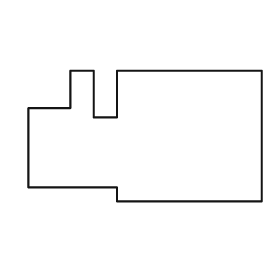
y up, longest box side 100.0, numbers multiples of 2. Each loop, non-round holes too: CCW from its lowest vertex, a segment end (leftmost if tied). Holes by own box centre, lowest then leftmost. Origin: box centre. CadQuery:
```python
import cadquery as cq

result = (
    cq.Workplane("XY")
    .moveTo(-12.0, -28.0)
    .lineTo(50.0, -28.0)
    .lineTo(50.0, 28.0)
    .lineTo(-12.0, 28.0)
    .lineTo(-12.0, 8.0)
    .lineTo(-22.0, 8.0)
    .lineTo(-22.0, 28.0)
    .lineTo(-32.0, 28.0)
    .lineTo(-32.0, 12.0)
    .lineTo(-50.0, 12.0)
    .lineTo(-50.0, -22.0)
    .lineTo(-12.0, -22.0)
    .close()
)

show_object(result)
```